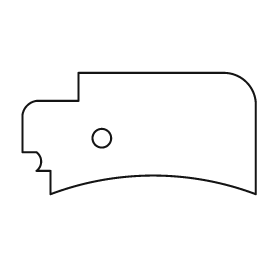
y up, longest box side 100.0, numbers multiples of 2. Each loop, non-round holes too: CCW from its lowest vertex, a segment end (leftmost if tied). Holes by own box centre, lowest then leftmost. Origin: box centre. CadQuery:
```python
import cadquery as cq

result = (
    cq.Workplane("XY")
    .moveTo(-38.0, -26.0)
    .threePointArc((6.0, -18.0), (50.0, -26.0))
    .lineTo(50.0, 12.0)
    .threePointArc((46.0, 22.0), (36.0, 26.0))
    .lineTo(-26.0, 26.0)
    .lineTo(-26.0, 14.0)
    .lineTo(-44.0, 14.0)
    .threePointArc((-48.0, 12.0), (-50.0, 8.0))
    .lineTo(-50.0, -8.0)
    .lineTo(-44.0, -8.0)
    .threePointArc((-42.0, -12.0), (-44.0, -16.0))
    .lineTo(-38.0, -16.0)
    .close()
    .moveTo(-16.0, -2.0)
    .circle(4.0)
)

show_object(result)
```